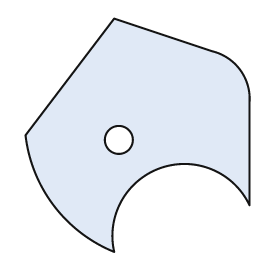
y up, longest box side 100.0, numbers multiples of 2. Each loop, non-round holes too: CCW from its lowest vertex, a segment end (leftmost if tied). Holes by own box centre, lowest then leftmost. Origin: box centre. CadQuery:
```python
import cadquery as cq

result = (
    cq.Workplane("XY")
    .moveTo(-10.0, -50.0)
    .threePointArc((10.0, -14.0), (48.0, -30.0))
    .lineTo(48.0, 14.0)
    .threePointArc((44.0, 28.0), (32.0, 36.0))
    .lineTo(-10.0, 50.0)
    .lineTo(-48.0, 0.0)
    .threePointArc((-36.0, -30.0), (-10.0, -50.0))
    .close()
    .moveTo(-8.0, -2.0)
    .circle(6.0)
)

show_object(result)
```